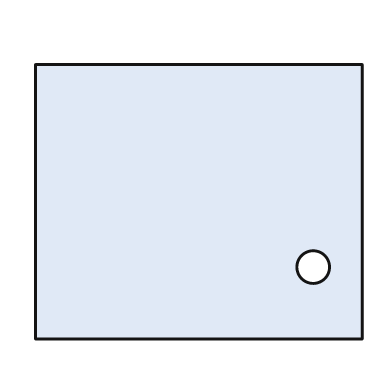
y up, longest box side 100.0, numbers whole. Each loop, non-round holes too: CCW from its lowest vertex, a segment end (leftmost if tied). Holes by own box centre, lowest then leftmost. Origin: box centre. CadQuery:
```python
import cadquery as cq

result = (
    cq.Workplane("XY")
    .moveTo(-50.0, -42.0)
    .lineTo(50.0, -42.0)
    .lineTo(50.0, 42.0)
    .lineTo(-50.0, 42.0)
    .close()
    .moveTo(35.0, -20.0)
    .circle(5.0)
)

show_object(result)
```